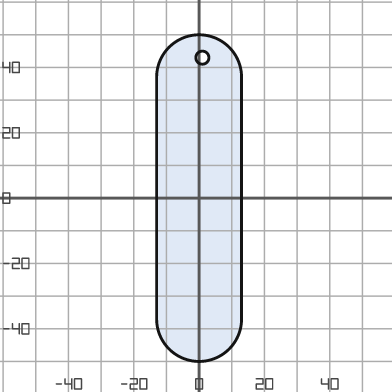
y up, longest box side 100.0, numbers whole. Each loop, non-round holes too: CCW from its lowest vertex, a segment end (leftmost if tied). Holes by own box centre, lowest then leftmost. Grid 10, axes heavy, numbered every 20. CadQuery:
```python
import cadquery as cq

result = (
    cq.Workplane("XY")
    .moveTo(-13.0, -37.0)
    .threePointArc((0.0, -50.0), (13.0, -37.0))
    .lineTo(13.0, 37.0)
    .threePointArc((0.0, 50.0), (-13.0, 37.0))
    .close()
    .moveTo(1.0, 43.0)
    .circle(2.0)
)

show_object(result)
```